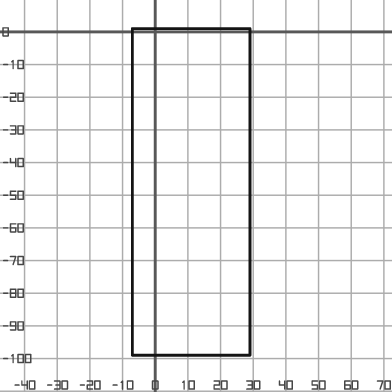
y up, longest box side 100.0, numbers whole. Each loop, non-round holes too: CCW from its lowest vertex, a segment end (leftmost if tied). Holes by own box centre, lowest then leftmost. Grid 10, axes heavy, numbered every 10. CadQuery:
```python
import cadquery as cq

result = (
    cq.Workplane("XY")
    .moveTo(-7.0, -99.0)
    .lineTo(29.0, -99.0)
    .lineTo(29.0, 1.0)
    .lineTo(-7.0, 1.0)
    .close()
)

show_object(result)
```